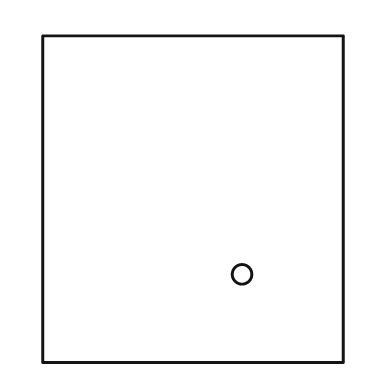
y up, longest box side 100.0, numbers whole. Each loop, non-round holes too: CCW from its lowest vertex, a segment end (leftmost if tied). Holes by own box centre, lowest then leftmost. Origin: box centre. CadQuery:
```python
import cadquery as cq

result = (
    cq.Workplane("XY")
    .moveTo(-46.0, -50.0)
    .lineTo(46.0, -50.0)
    .lineTo(46.0, 50.0)
    .lineTo(-46.0, 50.0)
    .close()
    .moveTo(15.0, -23.0)
    .circle(3.0)
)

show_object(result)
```